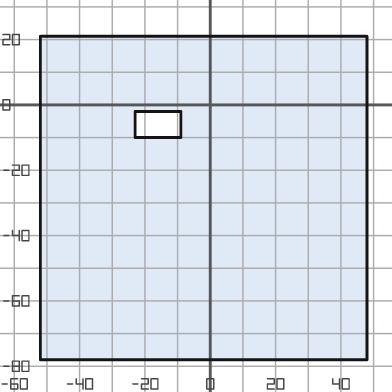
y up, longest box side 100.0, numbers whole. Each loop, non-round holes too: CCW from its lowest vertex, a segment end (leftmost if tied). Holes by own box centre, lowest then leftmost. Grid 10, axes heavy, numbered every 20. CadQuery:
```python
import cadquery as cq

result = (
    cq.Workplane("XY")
    .moveTo(-52.0, -78.0)
    .lineTo(48.0, -78.0)
    .lineTo(48.0, 21.0)
    .lineTo(-52.0, 21.0)
    .close()
    .moveTo(-23.0, -10.0)
    .lineTo(-9.0, -10.0)
    .lineTo(-9.0, -2.0)
    .lineTo(-23.0, -2.0)
    .close()
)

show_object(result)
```